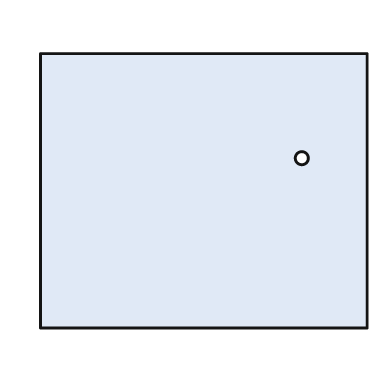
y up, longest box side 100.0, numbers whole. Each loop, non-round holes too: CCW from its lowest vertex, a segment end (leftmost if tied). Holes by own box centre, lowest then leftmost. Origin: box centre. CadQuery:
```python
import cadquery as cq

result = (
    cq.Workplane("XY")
    .moveTo(-50.0, -42.0)
    .lineTo(50.0, -42.0)
    .lineTo(50.0, 42.0)
    .lineTo(-50.0, 42.0)
    .close()
    .moveTo(30.0, 10.0)
    .circle(2.0)
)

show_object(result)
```